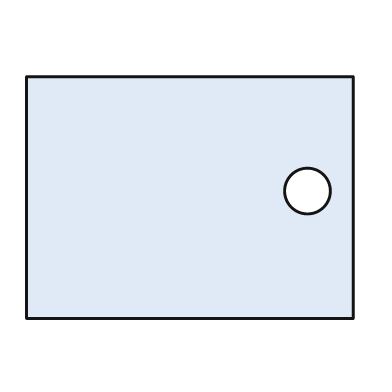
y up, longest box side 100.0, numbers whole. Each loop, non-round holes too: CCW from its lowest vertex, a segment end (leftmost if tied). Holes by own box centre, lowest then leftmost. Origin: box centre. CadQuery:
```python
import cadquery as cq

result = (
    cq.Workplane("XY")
    .moveTo(-50.0, -37.0)
    .lineTo(50.0, -37.0)
    .lineTo(50.0, 37.0)
    .lineTo(-50.0, 37.0)
    .close()
    .moveTo(36.0, 2.0)
    .circle(7.0)
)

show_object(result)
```